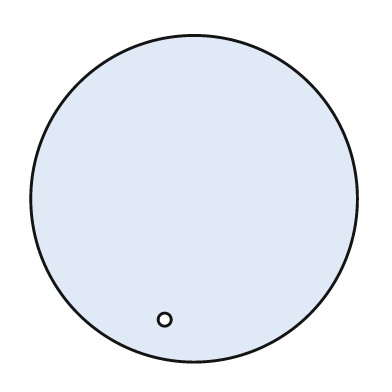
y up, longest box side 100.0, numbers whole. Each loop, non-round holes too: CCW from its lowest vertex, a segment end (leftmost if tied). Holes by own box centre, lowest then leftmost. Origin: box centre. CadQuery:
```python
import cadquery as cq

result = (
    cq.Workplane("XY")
    .moveTo(0.0, 0.0)
    .circle(50.0)
    .moveTo(-9.0, -37.0)
    .circle(2.0)
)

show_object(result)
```